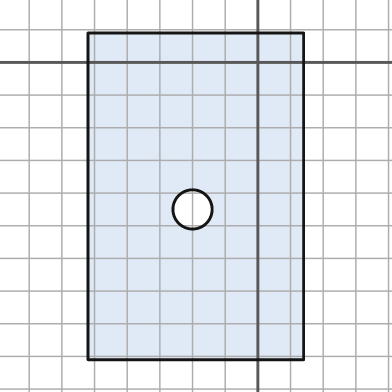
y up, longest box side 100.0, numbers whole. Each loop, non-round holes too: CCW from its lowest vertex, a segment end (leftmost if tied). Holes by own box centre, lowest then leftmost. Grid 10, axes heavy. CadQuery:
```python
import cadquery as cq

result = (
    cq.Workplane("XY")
    .moveTo(-52.0, -91.0)
    .lineTo(14.0, -91.0)
    .lineTo(14.0, 9.0)
    .lineTo(-52.0, 9.0)
    .close()
    .moveTo(-20.0, -45.0)
    .circle(6.0)
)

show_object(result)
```